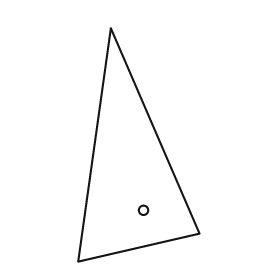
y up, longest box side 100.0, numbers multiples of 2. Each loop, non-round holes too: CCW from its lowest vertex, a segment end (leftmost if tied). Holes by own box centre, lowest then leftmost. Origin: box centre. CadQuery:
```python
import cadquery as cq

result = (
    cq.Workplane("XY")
    .moveTo(-26.0, -50.0)
    .lineTo(26.0, -38.0)
    .lineTo(-12.0, 50.0)
    .close()
    .moveTo(2.0, -28.0)
    .circle(2.0)
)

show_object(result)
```